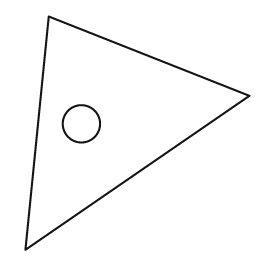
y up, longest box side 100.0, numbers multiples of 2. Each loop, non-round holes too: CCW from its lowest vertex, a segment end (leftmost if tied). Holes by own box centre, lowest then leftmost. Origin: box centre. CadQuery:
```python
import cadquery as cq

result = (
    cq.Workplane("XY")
    .moveTo(-48.0, -50.0)
    .lineTo(48.0, 16.0)
    .lineTo(-38.0, 50.0)
    .close()
    .moveTo(-24.0, 4.0)
    .circle(8.0)
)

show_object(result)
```